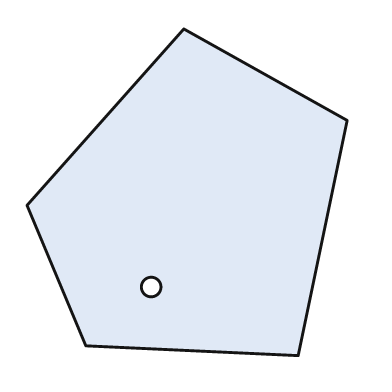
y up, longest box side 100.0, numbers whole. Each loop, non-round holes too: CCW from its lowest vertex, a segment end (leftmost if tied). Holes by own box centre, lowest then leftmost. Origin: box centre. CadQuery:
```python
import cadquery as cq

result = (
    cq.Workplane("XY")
    .moveTo(34.0, -50.0)
    .lineTo(49.0, 22.0)
    .lineTo(-1.0, 50.0)
    .lineTo(-49.0, -4.0)
    .lineTo(-31.0, -47.0)
    .close()
    .moveTo(-11.0, -29.0)
    .circle(3.0)
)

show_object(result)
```